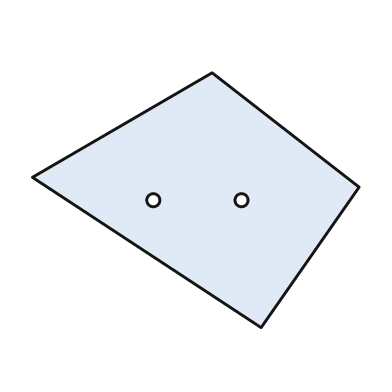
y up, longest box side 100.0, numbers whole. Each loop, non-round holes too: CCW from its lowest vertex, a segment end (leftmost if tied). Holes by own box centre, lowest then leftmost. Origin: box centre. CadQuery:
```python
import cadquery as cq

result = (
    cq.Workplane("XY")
    .moveTo(20.0, -39.0)
    .lineTo(50.0, 4.0)
    .lineTo(5.0, 39.0)
    .lineTo(-50.0, 7.0)
    .close()
    .moveTo(-13.0, 0.0)
    .circle(2.0)
    .moveTo(14.0, 0.0)
    .circle(2.0)
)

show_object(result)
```